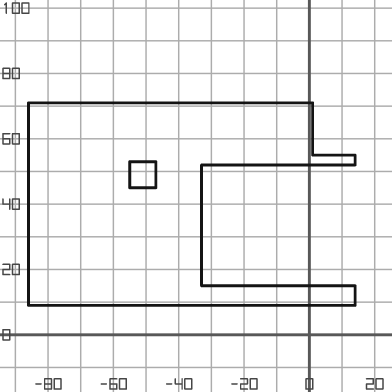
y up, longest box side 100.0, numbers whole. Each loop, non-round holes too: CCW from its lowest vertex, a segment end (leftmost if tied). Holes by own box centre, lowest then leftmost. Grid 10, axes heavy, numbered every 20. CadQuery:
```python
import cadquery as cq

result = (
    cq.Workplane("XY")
    .moveTo(-86.0, 9.0)
    .lineTo(14.0, 9.0)
    .lineTo(14.0, 15.0)
    .lineTo(-33.0, 15.0)
    .lineTo(-33.0, 52.0)
    .lineTo(14.0, 52.0)
    .lineTo(14.0, 55.0)
    .lineTo(1.0, 55.0)
    .lineTo(1.0, 71.0)
    .lineTo(-86.0, 71.0)
    .close()
    .moveTo(-55.0, 45.0)
    .lineTo(-47.0, 45.0)
    .lineTo(-47.0, 53.0)
    .lineTo(-55.0, 53.0)
    .close()
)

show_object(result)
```